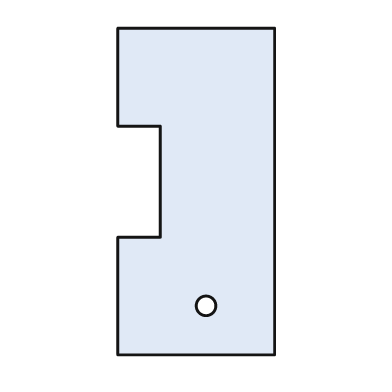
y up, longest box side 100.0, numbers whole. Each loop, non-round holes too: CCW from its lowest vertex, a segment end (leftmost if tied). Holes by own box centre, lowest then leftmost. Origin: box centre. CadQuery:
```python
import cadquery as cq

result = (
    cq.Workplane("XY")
    .moveTo(-24.0, -50.0)
    .lineTo(24.0, -50.0)
    .lineTo(24.0, 50.0)
    .lineTo(-24.0, 50.0)
    .lineTo(-24.0, 20.0)
    .lineTo(-11.0, 20.0)
    .lineTo(-11.0, -14.0)
    .lineTo(-24.0, -14.0)
    .close()
    .moveTo(3.0, -35.0)
    .circle(3.0)
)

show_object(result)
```